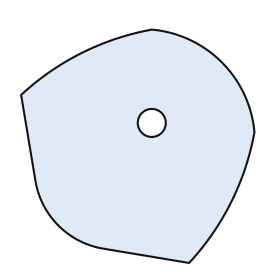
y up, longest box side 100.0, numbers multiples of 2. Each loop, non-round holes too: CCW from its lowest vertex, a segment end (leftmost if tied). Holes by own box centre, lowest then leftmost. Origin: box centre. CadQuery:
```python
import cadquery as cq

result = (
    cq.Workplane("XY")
    .moveTo(22.0, -50.0)
    .threePointArc((40.0, -24.0), (50.0, 6.0))
    .threePointArc((36.0, 36.0), (6.0, 50.0))
    .threePointArc((-24.0, 40.0), (-50.0, 22.0))
    .lineTo(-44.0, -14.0)
    .threePointArc((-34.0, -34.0), (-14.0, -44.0))
    .close()
    .moveTo(6.0, 10.0)
    .circle(6.0)
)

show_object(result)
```